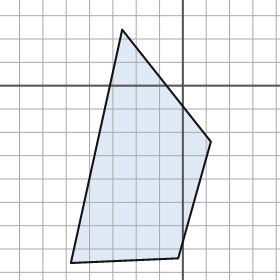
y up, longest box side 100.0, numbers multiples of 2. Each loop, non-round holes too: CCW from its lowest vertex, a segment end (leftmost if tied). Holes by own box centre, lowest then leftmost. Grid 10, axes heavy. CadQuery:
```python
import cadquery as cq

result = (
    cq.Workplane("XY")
    .moveTo(-48.0, -76.0)
    .lineTo(-2.0, -74.0)
    .lineTo(12.0, -24.0)
    .lineTo(-26.0, 24.0)
    .close()
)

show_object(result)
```